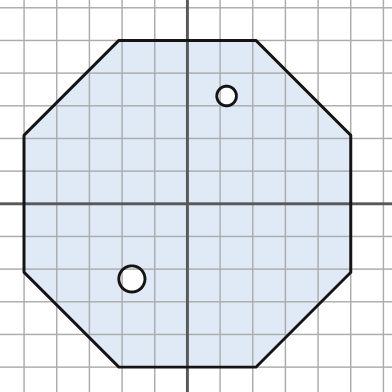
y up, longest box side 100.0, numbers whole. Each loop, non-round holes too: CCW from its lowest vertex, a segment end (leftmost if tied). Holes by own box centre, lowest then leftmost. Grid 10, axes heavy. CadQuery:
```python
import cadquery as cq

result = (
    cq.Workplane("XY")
    .moveTo(-21.0, -50.0)
    .lineTo(21.0, -50.0)
    .lineTo(50.0, -21.0)
    .lineTo(50.0, 21.0)
    .lineTo(21.0, 50.0)
    .lineTo(-21.0, 50.0)
    .lineTo(-50.0, 21.0)
    .lineTo(-50.0, -21.0)
    .close()
    .moveTo(-17.0, -23.0)
    .circle(4.0)
    .moveTo(12.0, 33.0)
    .circle(3.0)
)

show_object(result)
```